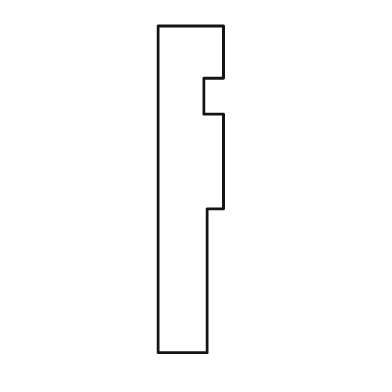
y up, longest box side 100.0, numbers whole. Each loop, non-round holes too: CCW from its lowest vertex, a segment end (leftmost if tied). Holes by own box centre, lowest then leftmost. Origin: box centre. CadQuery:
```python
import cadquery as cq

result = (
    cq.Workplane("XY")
    .moveTo(-10.0, -50.0)
    .lineTo(5.0, -50.0)
    .lineTo(5.0, -6.0)
    .lineTo(10.0, -6.0)
    .lineTo(10.0, 23.0)
    .lineTo(4.0, 23.0)
    .lineTo(4.0, 34.0)
    .lineTo(10.0, 34.0)
    .lineTo(10.0, 50.0)
    .lineTo(-10.0, 50.0)
    .close()
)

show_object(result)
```